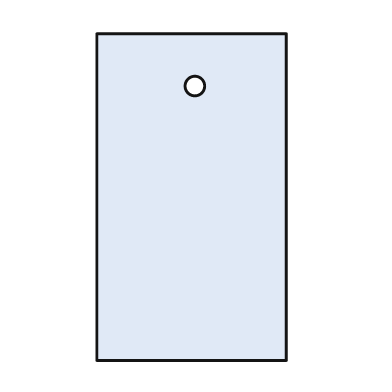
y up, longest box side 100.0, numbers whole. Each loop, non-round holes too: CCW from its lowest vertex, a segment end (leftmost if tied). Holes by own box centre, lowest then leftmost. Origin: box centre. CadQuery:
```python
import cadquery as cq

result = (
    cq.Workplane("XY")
    .moveTo(-29.0, -50.0)
    .lineTo(29.0, -50.0)
    .lineTo(29.0, 50.0)
    .lineTo(-29.0, 50.0)
    .close()
    .moveTo(1.0, 34.0)
    .circle(3.0)
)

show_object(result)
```